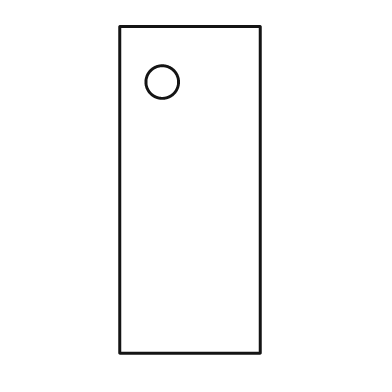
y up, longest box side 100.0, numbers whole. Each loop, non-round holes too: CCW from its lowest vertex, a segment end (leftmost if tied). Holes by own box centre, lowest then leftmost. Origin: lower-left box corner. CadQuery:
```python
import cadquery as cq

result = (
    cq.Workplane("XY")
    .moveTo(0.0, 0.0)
    .lineTo(43.0, 0.0)
    .lineTo(43.0, 100.0)
    .lineTo(0.0, 100.0)
    .close()
    .moveTo(13.0, 83.0)
    .circle(5.0)
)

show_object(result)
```